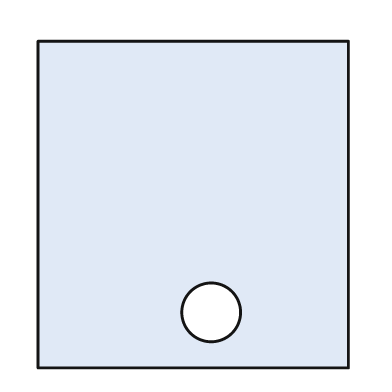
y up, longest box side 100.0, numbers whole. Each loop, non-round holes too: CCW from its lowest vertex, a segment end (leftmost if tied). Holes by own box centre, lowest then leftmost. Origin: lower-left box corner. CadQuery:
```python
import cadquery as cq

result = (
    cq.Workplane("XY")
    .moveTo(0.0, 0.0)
    .lineTo(95.0, 0.0)
    .lineTo(95.0, 100.0)
    .lineTo(0.0, 100.0)
    .close()
    .moveTo(53.0, 17.0)
    .circle(9.0)
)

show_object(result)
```